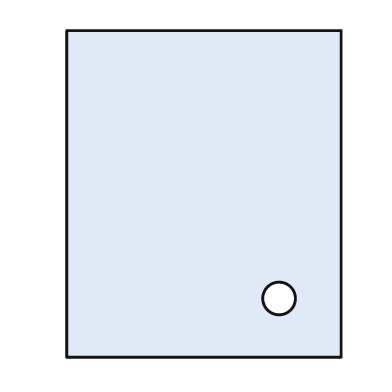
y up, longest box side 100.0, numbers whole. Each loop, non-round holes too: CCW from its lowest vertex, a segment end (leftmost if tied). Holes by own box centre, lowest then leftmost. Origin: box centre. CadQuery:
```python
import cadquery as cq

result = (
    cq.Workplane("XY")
    .moveTo(-42.0, -50.0)
    .lineTo(42.0, -50.0)
    .lineTo(42.0, 50.0)
    .lineTo(-42.0, 50.0)
    .close()
    .moveTo(23.0, -32.0)
    .circle(5.0)
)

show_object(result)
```